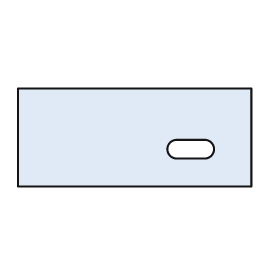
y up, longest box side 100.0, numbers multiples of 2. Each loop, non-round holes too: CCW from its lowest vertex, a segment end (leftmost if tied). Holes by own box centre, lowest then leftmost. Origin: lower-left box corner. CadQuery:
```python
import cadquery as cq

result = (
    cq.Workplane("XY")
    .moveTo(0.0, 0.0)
    .lineTo(100.0, 0.0)
    .lineTo(100.0, 42.0)
    .lineTo(0.0, 42.0)
    .close()
    .moveTo(68.0, 12.0)
    .lineTo(80.0, 12.0)
    .threePointArc((84.0, 16.0), (80.0, 20.0))
    .lineTo(68.0, 20.0)
    .threePointArc((64.0, 16.0), (68.0, 12.0))
    .close()
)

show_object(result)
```